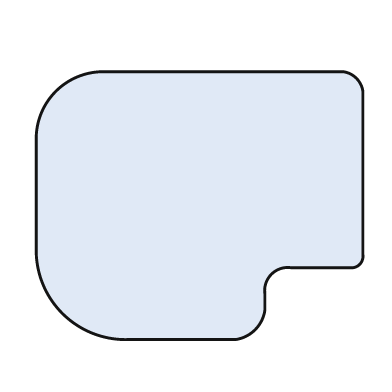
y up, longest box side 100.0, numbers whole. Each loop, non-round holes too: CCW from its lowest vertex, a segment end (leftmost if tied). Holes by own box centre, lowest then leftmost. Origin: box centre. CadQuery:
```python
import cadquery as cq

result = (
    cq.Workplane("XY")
    .moveTo(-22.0, -41.0)
    .lineTo(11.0, -41.0)
    .threePointArc((17.0, -38.0), (20.0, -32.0))
    .lineTo(20.0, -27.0)
    .threePointArc((22.0, -21.0), (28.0, -19.0))
    .lineTo(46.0, -19.0)
    .threePointArc((49.0, -18.0), (50.0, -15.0))
    .lineTo(50.0, 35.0)
    .threePointArc((48.0, 39.0), (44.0, 41.0))
    .lineTo(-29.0, 41.0)
    .threePointArc((-44.0, 35.0), (-50.0, 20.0))
    .lineTo(-50.0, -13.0)
    .threePointArc((-42.0, -33.0), (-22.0, -41.0))
    .close()
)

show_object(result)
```